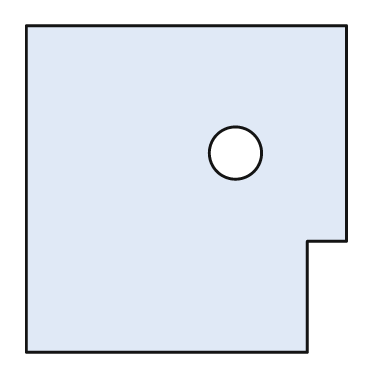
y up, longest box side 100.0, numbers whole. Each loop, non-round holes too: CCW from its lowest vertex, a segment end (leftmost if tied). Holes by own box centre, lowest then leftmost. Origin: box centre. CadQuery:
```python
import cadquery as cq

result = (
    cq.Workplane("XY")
    .moveTo(-49.0, -50.0)
    .lineTo(37.0, -50.0)
    .lineTo(37.0, -16.0)
    .lineTo(49.0, -16.0)
    .lineTo(49.0, 50.0)
    .lineTo(-49.0, 50.0)
    .close()
    .moveTo(15.0, 11.0)
    .circle(8.0)
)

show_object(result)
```